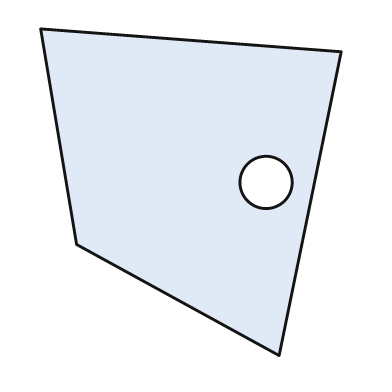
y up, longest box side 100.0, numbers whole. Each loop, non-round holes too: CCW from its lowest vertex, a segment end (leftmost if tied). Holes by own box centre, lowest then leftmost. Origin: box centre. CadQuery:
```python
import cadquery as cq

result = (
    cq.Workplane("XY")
    .moveTo(27.0, -50.0)
    .lineTo(46.0, 43.0)
    .lineTo(-46.0, 50.0)
    .lineTo(-35.0, -16.0)
    .close()
    .moveTo(23.0, 3.0)
    .circle(8.0)
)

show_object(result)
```